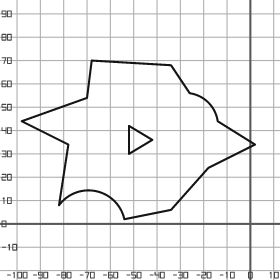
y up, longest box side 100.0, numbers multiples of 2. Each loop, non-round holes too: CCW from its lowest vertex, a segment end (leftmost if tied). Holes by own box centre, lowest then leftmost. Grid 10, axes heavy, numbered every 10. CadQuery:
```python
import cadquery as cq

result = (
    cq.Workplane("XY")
    .moveTo(-54.0, 2.0)
    .lineTo(-34.0, 6.0)
    .lineTo(-18.0, 24.0)
    .lineTo(2.0, 34.0)
    .lineTo(-14.0, 44.0)
    .threePointArc((-18.0, 52.0), (-26.0, 56.0))
    .lineTo(-34.0, 68.0)
    .lineTo(-68.0, 70.0)
    .lineTo(-70.0, 54.0)
    .lineTo(-98.0, 44.0)
    .lineTo(-78.0, 34.0)
    .lineTo(-82.0, 8.0)
    .threePointArc((-66.0, 14.0), (-54.0, 2.0))
    .close()
    .moveTo(-52.0, 30.0)
    .lineTo(-42.0, 36.0)
    .lineTo(-52.0, 42.0)
    .close()
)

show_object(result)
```